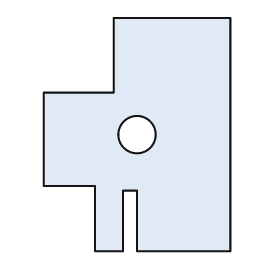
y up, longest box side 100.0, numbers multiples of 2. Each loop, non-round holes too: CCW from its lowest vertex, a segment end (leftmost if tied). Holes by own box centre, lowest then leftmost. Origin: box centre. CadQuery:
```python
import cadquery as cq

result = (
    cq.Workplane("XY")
    .moveTo(-18.0, -50.0)
    .lineTo(-6.0, -50.0)
    .lineTo(-6.0, -24.0)
    .lineTo(0.0, -24.0)
    .lineTo(0.0, -50.0)
    .lineTo(40.0, -50.0)
    .lineTo(40.0, 50.0)
    .lineTo(-10.0, 50.0)
    .lineTo(-10.0, 18.0)
    .lineTo(-40.0, 18.0)
    .lineTo(-40.0, -22.0)
    .lineTo(-18.0, -22.0)
    .close()
    .moveTo(0.0, 0.0)
    .circle(8.0)
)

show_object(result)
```